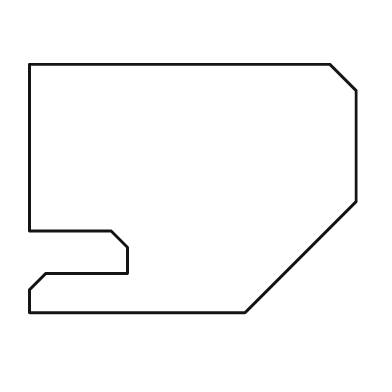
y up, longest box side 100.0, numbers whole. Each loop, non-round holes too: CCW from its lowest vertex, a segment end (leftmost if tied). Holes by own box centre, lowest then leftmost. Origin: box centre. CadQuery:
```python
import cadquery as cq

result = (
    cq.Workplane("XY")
    .moveTo(-50.0, -38.0)
    .lineTo(16.0, -38.0)
    .lineTo(50.0, -4.0)
    .lineTo(50.0, 30.0)
    .lineTo(42.0, 38.0)
    .lineTo(-50.0, 38.0)
    .lineTo(-50.0, -13.0)
    .lineTo(-25.0, -13.0)
    .lineTo(-20.0, -18.0)
    .lineTo(-20.0, -26.0)
    .lineTo(-45.0, -26.0)
    .lineTo(-50.0, -31.0)
    .close()
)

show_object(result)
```